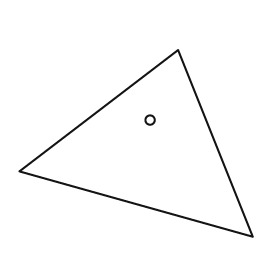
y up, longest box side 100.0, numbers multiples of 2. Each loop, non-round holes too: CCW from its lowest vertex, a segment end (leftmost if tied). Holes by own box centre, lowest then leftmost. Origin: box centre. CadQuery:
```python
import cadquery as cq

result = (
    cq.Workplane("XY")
    .moveTo(50.0, -40.0)
    .lineTo(18.0, 40.0)
    .lineTo(-50.0, -12.0)
    .close()
    .moveTo(6.0, 10.0)
    .circle(2.0)
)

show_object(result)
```